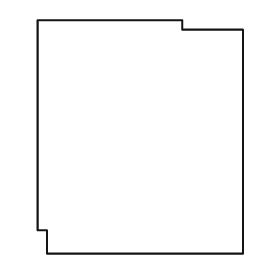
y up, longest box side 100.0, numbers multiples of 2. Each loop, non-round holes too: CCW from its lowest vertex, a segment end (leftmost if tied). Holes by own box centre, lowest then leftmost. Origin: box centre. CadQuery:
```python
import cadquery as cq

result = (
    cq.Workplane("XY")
    .moveTo(-40.0, -50.0)
    .lineTo(44.0, -50.0)
    .lineTo(44.0, 46.0)
    .lineTo(18.0, 46.0)
    .lineTo(18.0, 50.0)
    .lineTo(-44.0, 50.0)
    .lineTo(-44.0, -40.0)
    .lineTo(-40.0, -40.0)
    .close()
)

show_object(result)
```